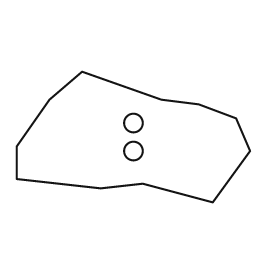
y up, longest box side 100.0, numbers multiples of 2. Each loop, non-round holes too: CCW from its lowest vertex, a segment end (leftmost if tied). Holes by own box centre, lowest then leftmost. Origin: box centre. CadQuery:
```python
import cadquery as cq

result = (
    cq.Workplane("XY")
    .moveTo(34.0, -28.0)
    .lineTo(50.0, -6.0)
    .lineTo(44.0, 8.0)
    .lineTo(28.0, 14.0)
    .lineTo(12.0, 16.0)
    .lineTo(-22.0, 28.0)
    .lineTo(-36.0, 16.0)
    .lineTo(-50.0, -4.0)
    .lineTo(-50.0, -18.0)
    .lineTo(-14.0, -22.0)
    .lineTo(4.0, -20.0)
    .close()
    .moveTo(0.0, -6.0)
    .circle(4.0)
    .moveTo(0.0, 6.0)
    .circle(4.0)
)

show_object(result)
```